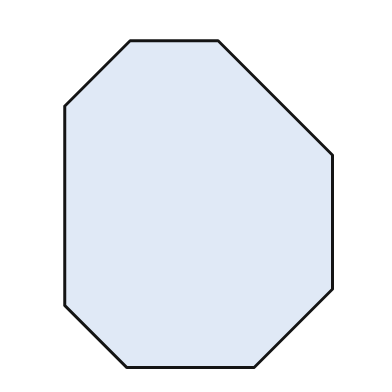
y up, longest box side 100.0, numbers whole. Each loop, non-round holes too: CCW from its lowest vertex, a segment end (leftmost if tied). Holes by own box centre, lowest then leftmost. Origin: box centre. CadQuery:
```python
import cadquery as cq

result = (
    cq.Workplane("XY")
    .moveTo(-22.0, -50.0)
    .lineTo(17.0, -50.0)
    .lineTo(41.0, -26.0)
    .lineTo(41.0, 15.0)
    .lineTo(6.0, 50.0)
    .lineTo(-21.0, 50.0)
    .lineTo(-41.0, 30.0)
    .lineTo(-41.0, -31.0)
    .close()
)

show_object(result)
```